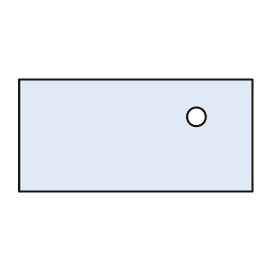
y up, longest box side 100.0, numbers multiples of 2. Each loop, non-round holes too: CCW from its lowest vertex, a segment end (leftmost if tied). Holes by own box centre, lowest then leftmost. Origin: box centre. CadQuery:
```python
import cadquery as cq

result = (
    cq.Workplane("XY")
    .moveTo(-50.0, -24.0)
    .lineTo(50.0, -24.0)
    .lineTo(50.0, 24.0)
    .lineTo(-50.0, 24.0)
    .close()
    .moveTo(26.0, 8.0)
    .circle(4.0)
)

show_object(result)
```